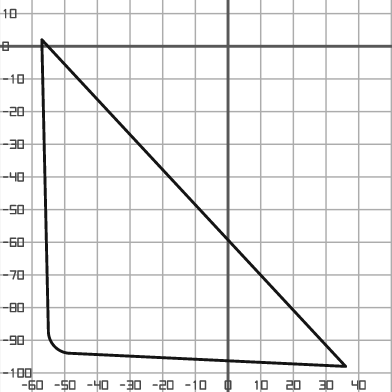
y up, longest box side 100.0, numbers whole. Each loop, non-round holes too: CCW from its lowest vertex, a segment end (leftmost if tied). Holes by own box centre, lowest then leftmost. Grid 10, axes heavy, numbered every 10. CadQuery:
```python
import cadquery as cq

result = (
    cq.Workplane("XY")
    .moveTo(36.0, -98.0)
    .lineTo(-57.0, 2.0)
    .lineTo(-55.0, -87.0)
    .threePointArc((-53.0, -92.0), (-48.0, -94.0))
    .close()
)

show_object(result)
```